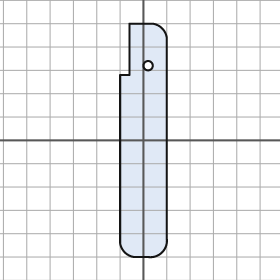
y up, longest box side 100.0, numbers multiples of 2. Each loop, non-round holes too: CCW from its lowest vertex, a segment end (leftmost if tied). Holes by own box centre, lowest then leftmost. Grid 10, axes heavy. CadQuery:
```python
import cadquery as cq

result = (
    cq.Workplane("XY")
    .moveTo(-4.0, -50.0)
    .lineTo(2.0, -50.0)
    .threePointArc((8.0, -48.0), (10.0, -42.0))
    .lineTo(10.0, 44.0)
    .threePointArc((8.0, 48.0), (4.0, 50.0))
    .lineTo(-6.0, 50.0)
    .lineTo(-6.0, 28.0)
    .lineTo(-10.0, 28.0)
    .lineTo(-10.0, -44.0)
    .threePointArc((-8.0, -48.0), (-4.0, -50.0))
    .close()
    .moveTo(2.0, 32.0)
    .circle(2.0)
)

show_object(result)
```